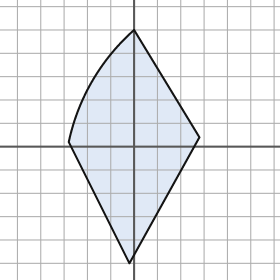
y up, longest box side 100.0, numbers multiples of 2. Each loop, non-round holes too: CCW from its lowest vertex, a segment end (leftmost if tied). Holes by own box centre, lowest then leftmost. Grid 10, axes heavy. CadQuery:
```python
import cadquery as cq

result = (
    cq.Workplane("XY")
    .moveTo(-2.0, -50.0)
    .lineTo(28.0, 4.0)
    .lineTo(0.0, 50.0)
    .threePointArc((-18.0, 28.0), (-28.0, 2.0))
    .close()
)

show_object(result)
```